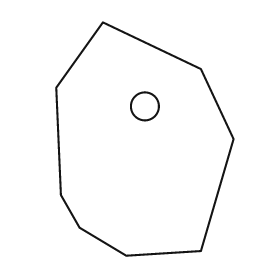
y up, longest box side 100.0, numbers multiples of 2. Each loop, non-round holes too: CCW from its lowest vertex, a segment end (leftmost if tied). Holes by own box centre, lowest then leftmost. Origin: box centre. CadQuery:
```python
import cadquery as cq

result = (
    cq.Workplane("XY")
    .moveTo(-8.0, -50.0)
    .lineTo(24.0, -48.0)
    .lineTo(38.0, 0.0)
    .lineTo(24.0, 30.0)
    .lineTo(-18.0, 50.0)
    .lineTo(-38.0, 22.0)
    .lineTo(-36.0, -24.0)
    .lineTo(-28.0, -38.0)
    .close()
    .moveTo(0.0, 14.0)
    .circle(6.0)
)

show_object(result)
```